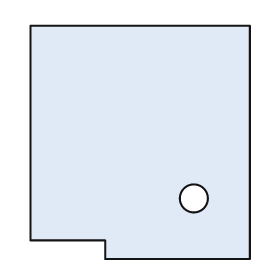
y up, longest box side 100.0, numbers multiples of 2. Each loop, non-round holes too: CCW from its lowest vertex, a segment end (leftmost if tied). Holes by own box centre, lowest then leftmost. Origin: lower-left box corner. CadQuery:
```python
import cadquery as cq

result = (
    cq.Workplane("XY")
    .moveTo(32.0, 0.0)
    .lineTo(94.0, 0.0)
    .lineTo(94.0, 100.0)
    .lineTo(0.0, 100.0)
    .lineTo(0.0, 8.0)
    .lineTo(32.0, 8.0)
    .close()
    .moveTo(70.0, 26.0)
    .circle(6.0)
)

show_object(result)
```